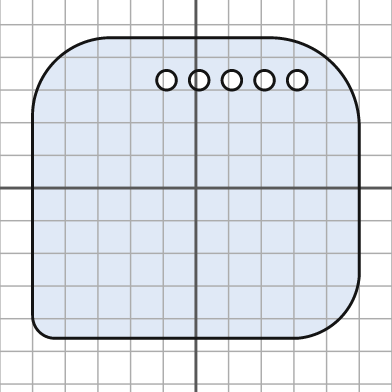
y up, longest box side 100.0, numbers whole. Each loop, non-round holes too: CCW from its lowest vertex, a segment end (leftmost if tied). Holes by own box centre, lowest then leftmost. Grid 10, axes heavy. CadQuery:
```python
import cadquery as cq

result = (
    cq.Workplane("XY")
    .moveTo(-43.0, -46.0)
    .lineTo(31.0, -46.0)
    .threePointArc((44.0, -40.0), (50.0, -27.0))
    .lineTo(50.0, 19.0)
    .threePointArc((42.0, 38.0), (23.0, 46.0))
    .lineTo(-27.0, 46.0)
    .threePointArc((-43.0, 39.0), (-50.0, 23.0))
    .lineTo(-50.0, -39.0)
    .threePointArc((-48.0, -44.0), (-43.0, -46.0))
    .close()
    .moveTo(-9.0, 33.0)
    .circle(3.0)
    .moveTo(1.0, 33.0)
    .circle(3.0)
    .moveTo(11.0, 33.0)
    .circle(3.0)
    .moveTo(21.0, 33.0)
    .circle(3.0)
    .moveTo(31.0, 33.0)
    .circle(3.0)
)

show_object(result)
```